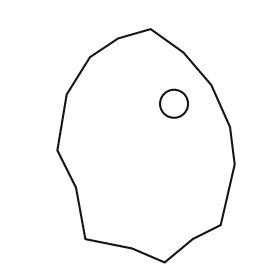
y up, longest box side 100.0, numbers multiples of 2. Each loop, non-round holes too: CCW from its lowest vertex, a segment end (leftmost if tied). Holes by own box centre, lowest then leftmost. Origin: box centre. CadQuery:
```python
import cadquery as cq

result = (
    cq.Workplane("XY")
    .moveTo(8.0, -50.0)
    .lineTo(20.0, -40.0)
    .lineTo(32.0, -34.0)
    .lineTo(38.0, -8.0)
    .lineTo(36.0, 8.0)
    .lineTo(28.0, 26.0)
    .lineTo(16.0, 40.0)
    .lineTo(2.0, 50.0)
    .lineTo(-12.0, 46.0)
    .lineTo(-24.0, 38.0)
    .lineTo(-34.0, 22.0)
    .lineTo(-38.0, -2.0)
    .lineTo(-30.0, -18.0)
    .lineTo(-26.0, -40.0)
    .lineTo(-6.0, -44.0)
    .close()
    .moveTo(12.0, 18.0)
    .circle(6.0)
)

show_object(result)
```